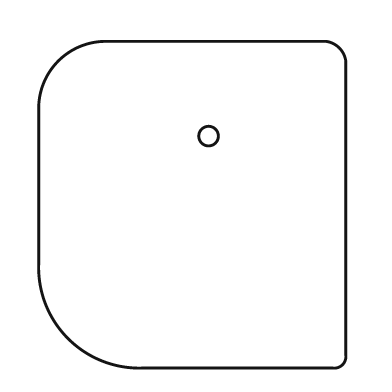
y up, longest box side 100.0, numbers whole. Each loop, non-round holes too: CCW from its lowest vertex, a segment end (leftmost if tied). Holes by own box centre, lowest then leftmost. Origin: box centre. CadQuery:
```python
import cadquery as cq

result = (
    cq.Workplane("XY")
    .moveTo(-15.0, -50.0)
    .lineTo(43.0, -50.0)
    .threePointArc((46.0, -49.0), (47.0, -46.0))
    .lineTo(47.0, 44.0)
    .threePointArc((45.0, 48.0), (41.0, 50.0))
    .lineTo(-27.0, 50.0)
    .threePointArc((-41.0, 44.0), (-47.0, 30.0))
    .lineTo(-47.0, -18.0)
    .threePointArc((-38.0, -41.0), (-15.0, -50.0))
    .close()
    .moveTo(5.0, 21.0)
    .circle(3.0)
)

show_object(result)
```